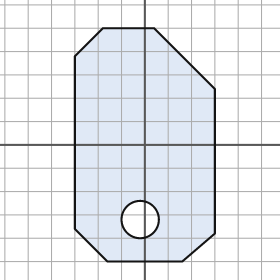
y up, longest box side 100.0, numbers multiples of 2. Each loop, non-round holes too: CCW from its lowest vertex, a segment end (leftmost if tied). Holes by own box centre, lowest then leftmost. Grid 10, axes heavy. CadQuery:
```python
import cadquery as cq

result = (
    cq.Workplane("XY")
    .moveTo(-16.0, -50.0)
    .lineTo(16.0, -50.0)
    .lineTo(30.0, -38.0)
    .lineTo(30.0, 24.0)
    .lineTo(4.0, 50.0)
    .lineTo(-18.0, 50.0)
    .lineTo(-30.0, 38.0)
    .lineTo(-30.0, -36.0)
    .close()
    .moveTo(-2.0, -32.0)
    .circle(8.0)
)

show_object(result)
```